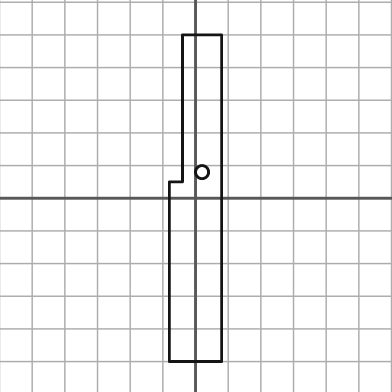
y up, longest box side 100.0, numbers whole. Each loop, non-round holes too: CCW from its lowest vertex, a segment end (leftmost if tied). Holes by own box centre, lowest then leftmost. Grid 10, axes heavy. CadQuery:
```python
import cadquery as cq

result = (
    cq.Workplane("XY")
    .moveTo(-8.0, -50.0)
    .lineTo(8.0, -50.0)
    .lineTo(8.0, 50.0)
    .lineTo(-4.0, 50.0)
    .lineTo(-4.0, 5.0)
    .lineTo(-8.0, 5.0)
    .close()
    .moveTo(2.0, 8.0)
    .circle(2.0)
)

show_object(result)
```